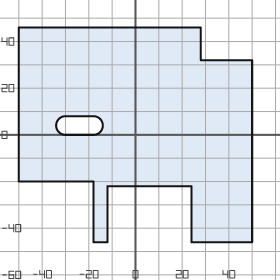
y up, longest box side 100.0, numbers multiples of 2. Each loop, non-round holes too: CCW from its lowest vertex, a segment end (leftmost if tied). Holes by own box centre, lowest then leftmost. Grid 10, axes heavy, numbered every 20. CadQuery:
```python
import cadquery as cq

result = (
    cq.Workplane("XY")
    .moveTo(-18.0, -46.0)
    .lineTo(-12.0, -46.0)
    .lineTo(-12.0, -22.0)
    .lineTo(24.0, -22.0)
    .lineTo(24.0, -46.0)
    .lineTo(50.0, -46.0)
    .lineTo(50.0, 32.0)
    .lineTo(28.0, 32.0)
    .lineTo(28.0, 46.0)
    .lineTo(-50.0, 46.0)
    .lineTo(-50.0, -20.0)
    .lineTo(-18.0, -20.0)
    .close()
    .moveTo(-30.0, 0.0)
    .lineTo(-18.0, 0.0)
    .threePointArc((-14.0, 4.0), (-18.0, 8.0))
    .lineTo(-30.0, 8.0)
    .threePointArc((-34.0, 4.0), (-30.0, 0.0))
    .close()
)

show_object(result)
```